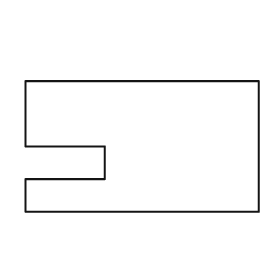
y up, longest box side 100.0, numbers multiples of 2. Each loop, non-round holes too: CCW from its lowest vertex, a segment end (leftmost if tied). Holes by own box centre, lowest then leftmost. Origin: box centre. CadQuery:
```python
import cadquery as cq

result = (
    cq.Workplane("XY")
    .moveTo(-50.0, -28.0)
    .lineTo(50.0, -28.0)
    .lineTo(50.0, 28.0)
    .lineTo(-50.0, 28.0)
    .lineTo(-50.0, 0.0)
    .lineTo(-16.0, 0.0)
    .lineTo(-16.0, -14.0)
    .lineTo(-50.0, -14.0)
    .close()
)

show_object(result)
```